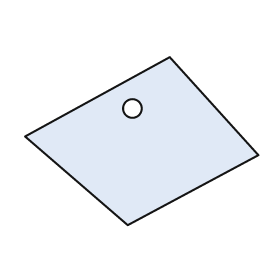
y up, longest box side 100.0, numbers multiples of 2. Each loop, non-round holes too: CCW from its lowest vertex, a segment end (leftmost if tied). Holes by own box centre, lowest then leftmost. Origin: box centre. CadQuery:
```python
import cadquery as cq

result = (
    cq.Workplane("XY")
    .moveTo(-6.0, -36.0)
    .lineTo(50.0, -6.0)
    .lineTo(12.0, 36.0)
    .lineTo(-50.0, 2.0)
    .close()
    .moveTo(-4.0, 14.0)
    .circle(4.0)
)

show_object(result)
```